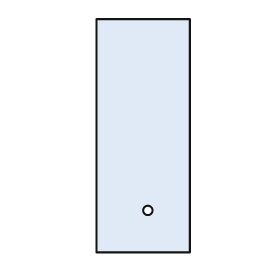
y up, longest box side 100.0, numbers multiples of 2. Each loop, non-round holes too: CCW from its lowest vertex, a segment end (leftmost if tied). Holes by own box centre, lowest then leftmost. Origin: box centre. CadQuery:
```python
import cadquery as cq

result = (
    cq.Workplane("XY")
    .moveTo(-20.0, -50.0)
    .lineTo(20.0, -50.0)
    .lineTo(20.0, 50.0)
    .lineTo(-20.0, 50.0)
    .close()
    .moveTo(2.0, -32.0)
    .circle(2.0)
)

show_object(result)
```